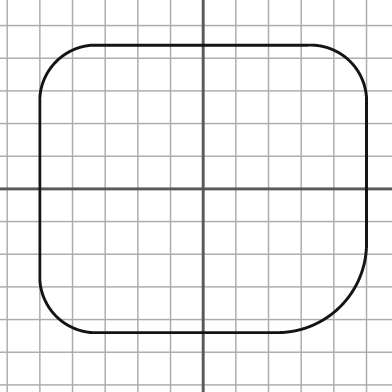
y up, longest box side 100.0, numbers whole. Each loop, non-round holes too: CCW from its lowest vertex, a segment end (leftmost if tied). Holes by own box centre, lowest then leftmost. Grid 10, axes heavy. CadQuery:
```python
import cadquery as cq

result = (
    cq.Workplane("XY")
    .moveTo(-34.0, -44.0)
    .lineTo(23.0, -44.0)
    .threePointArc((42.0, -36.0), (50.0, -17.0))
    .lineTo(50.0, 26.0)
    .threePointArc((45.0, 39.0), (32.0, 44.0))
    .lineTo(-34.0, 44.0)
    .threePointArc((-45.0, 39.0), (-50.0, 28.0))
    .lineTo(-50.0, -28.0)
    .threePointArc((-45.0, -39.0), (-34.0, -44.0))
    .close()
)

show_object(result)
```